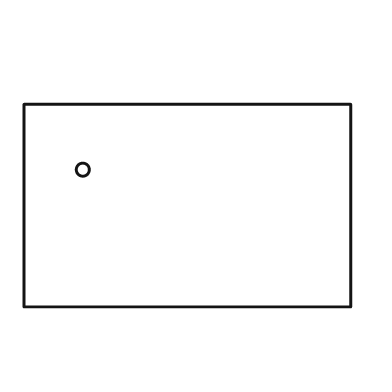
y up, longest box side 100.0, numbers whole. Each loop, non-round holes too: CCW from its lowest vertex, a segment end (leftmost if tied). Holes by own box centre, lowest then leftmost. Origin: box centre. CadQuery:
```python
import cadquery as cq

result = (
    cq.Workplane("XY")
    .moveTo(-50.0, -31.0)
    .lineTo(50.0, -31.0)
    .lineTo(50.0, 31.0)
    .lineTo(-50.0, 31.0)
    .close()
    .moveTo(-32.0, 11.0)
    .circle(2.0)
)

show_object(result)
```